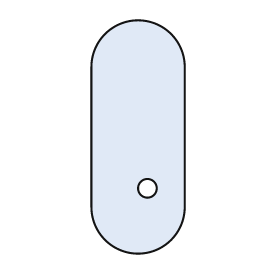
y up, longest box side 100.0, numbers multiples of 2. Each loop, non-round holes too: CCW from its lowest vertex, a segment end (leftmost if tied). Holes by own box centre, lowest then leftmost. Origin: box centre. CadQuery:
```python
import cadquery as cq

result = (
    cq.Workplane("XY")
    .moveTo(-20.0, -30.0)
    .threePointArc((0.0, -50.0), (20.0, -30.0))
    .lineTo(20.0, 30.0)
    .threePointArc((0.0, 50.0), (-20.0, 30.0))
    .close()
    .moveTo(4.0, -22.0)
    .circle(4.0)
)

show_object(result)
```